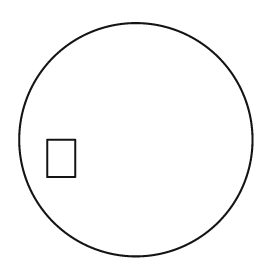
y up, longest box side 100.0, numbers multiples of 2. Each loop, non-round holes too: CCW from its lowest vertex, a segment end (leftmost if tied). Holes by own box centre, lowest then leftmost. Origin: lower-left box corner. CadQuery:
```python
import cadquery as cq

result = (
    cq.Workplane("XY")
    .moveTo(50.0, 50.0)
    .circle(50.0)
    .moveTo(12.0, 34.0)
    .lineTo(24.0, 34.0)
    .lineTo(24.0, 50.0)
    .lineTo(12.0, 50.0)
    .close()
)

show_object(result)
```